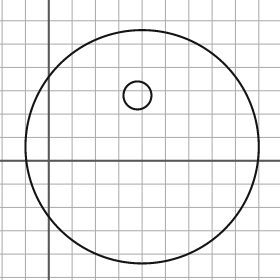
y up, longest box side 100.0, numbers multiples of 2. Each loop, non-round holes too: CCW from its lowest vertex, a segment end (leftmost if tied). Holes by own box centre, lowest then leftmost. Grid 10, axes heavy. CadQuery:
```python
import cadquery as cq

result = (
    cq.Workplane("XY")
    .moveTo(40.0, 6.0)
    .circle(50.0)
    .moveTo(38.0, 28.0)
    .circle(6.0)
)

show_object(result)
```